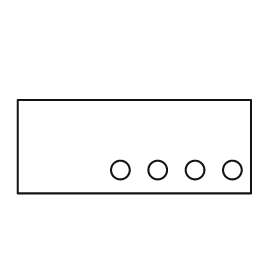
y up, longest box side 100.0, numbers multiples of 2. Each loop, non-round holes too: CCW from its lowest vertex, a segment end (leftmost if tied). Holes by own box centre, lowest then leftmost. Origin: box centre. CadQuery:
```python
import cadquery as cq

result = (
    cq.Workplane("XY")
    .moveTo(-50.0, -20.0)
    .lineTo(50.0, -20.0)
    .lineTo(50.0, 20.0)
    .lineTo(-50.0, 20.0)
    .close()
    .moveTo(-6.0, -10.0)
    .circle(4.0)
    .moveTo(10.0, -10.0)
    .circle(4.0)
    .moveTo(26.0, -10.0)
    .circle(4.0)
    .moveTo(42.0, -10.0)
    .circle(4.0)
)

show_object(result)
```